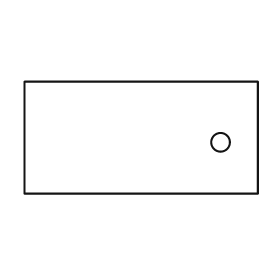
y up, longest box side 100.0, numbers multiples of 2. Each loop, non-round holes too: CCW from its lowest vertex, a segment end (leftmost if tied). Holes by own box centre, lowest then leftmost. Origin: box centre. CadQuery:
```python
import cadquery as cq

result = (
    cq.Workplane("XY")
    .moveTo(-50.0, -24.0)
    .lineTo(50.0, -24.0)
    .lineTo(50.0, 24.0)
    .lineTo(-50.0, 24.0)
    .close()
    .moveTo(34.0, -2.0)
    .circle(4.0)
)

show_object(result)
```